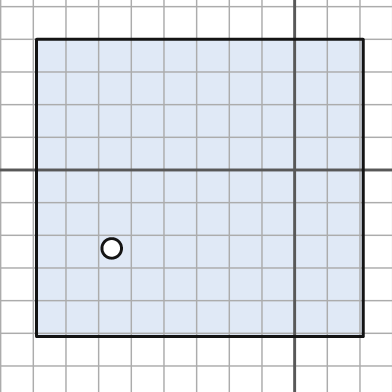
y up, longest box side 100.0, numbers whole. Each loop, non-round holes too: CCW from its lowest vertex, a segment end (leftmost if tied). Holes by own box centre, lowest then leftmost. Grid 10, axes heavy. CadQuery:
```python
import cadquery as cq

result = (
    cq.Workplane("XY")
    .moveTo(-79.0, -51.0)
    .lineTo(21.0, -51.0)
    .lineTo(21.0, 40.0)
    .lineTo(-79.0, 40.0)
    .close()
    .moveTo(-56.0, -24.0)
    .circle(3.0)
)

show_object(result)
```